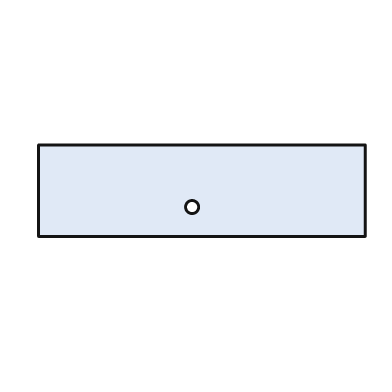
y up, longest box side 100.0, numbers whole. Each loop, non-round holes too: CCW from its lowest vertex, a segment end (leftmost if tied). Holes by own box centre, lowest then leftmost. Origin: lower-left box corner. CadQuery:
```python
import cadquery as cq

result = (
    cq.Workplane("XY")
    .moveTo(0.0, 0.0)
    .lineTo(100.0, 0.0)
    .lineTo(100.0, 28.0)
    .lineTo(0.0, 28.0)
    .close()
    .moveTo(47.0, 9.0)
    .circle(2.0)
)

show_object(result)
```